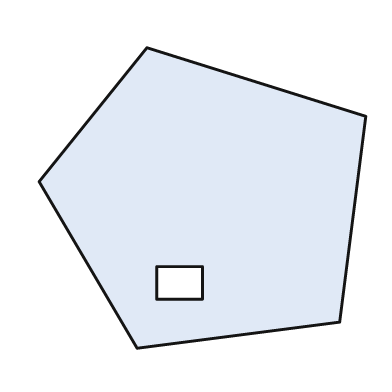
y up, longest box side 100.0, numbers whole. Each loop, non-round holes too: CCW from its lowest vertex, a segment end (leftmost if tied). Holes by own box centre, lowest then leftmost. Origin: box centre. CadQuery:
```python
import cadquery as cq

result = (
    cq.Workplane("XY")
    .moveTo(-20.0, -46.0)
    .lineTo(42.0, -38.0)
    .lineTo(50.0, 25.0)
    .lineTo(-17.0, 46.0)
    .lineTo(-50.0, 5.0)
    .close()
    .moveTo(-14.0, -31.0)
    .lineTo(0.0, -31.0)
    .lineTo(0.0, -21.0)
    .lineTo(-14.0, -21.0)
    .close()
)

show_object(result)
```